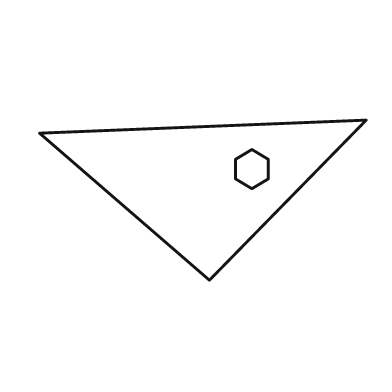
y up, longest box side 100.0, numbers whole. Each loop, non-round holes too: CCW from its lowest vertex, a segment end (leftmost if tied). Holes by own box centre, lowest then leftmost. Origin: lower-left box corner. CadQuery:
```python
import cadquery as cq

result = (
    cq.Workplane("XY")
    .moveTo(52.0, 0.0)
    .lineTo(100.0, 49.0)
    .lineTo(0.0, 45.0)
    .close()
    .moveTo(65.0, 28.0)
    .lineTo(70.0, 31.0)
    .lineTo(70.0, 37.0)
    .lineTo(65.0, 40.0)
    .lineTo(60.0, 37.0)
    .lineTo(60.0, 31.0)
    .close()
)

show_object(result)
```